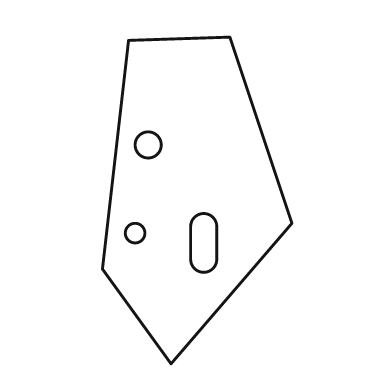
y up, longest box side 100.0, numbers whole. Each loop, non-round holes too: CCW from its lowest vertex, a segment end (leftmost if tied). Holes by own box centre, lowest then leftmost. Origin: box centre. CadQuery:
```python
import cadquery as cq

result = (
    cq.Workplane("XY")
    .moveTo(-8.0, -50.0)
    .lineTo(29.0, -7.0)
    .lineTo(10.0, 50.0)
    .lineTo(-21.0, 49.0)
    .lineTo(-29.0, -21.0)
    .close()
    .moveTo(-2.0, -18.0)
    .threePointArc((2.0, -22.0), (6.0, -18.0))
    .lineTo(6.0, -8.0)
    .threePointArc((2.0, -4.0), (-2.0, -8.0))
    .close()
    .moveTo(-19.0, -10.0)
    .circle(3.0)
    .moveTo(-15.0, 17.0)
    .circle(4.0)
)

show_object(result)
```